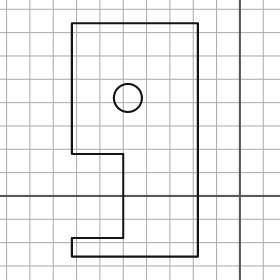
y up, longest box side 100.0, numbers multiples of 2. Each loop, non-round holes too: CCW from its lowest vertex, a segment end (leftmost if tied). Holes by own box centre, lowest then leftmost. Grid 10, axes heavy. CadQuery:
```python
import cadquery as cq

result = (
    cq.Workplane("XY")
    .moveTo(-72.0, -26.0)
    .lineTo(-18.0, -26.0)
    .lineTo(-18.0, 74.0)
    .lineTo(-72.0, 74.0)
    .lineTo(-72.0, 18.0)
    .lineTo(-50.0, 18.0)
    .lineTo(-50.0, -18.0)
    .lineTo(-72.0, -18.0)
    .close()
    .moveTo(-48.0, 42.0)
    .circle(6.0)
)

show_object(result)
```